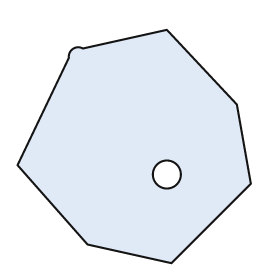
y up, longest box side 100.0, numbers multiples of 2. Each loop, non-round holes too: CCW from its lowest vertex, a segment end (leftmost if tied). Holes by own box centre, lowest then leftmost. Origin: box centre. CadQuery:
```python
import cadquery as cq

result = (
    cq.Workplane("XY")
    .moveTo(16.0, -50.0)
    .lineTo(50.0, -16.0)
    .lineTo(44.0, 18.0)
    .lineTo(14.0, 50.0)
    .lineTo(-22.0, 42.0)
    .threePointArc((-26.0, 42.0), (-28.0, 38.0))
    .lineTo(-50.0, -8.0)
    .lineTo(-20.0, -42.0)
    .close()
    .moveTo(14.0, -12.0)
    .circle(6.0)
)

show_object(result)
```